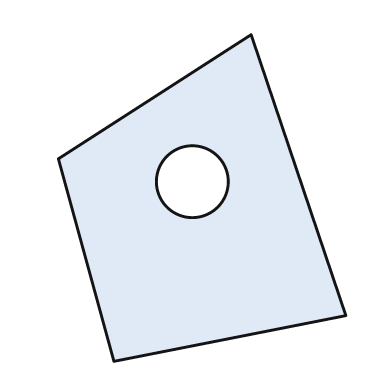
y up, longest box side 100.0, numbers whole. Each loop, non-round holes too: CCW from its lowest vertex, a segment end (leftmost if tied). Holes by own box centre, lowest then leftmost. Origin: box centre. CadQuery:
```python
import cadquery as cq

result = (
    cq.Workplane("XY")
    .moveTo(-27.0, -50.0)
    .lineTo(44.0, -36.0)
    .lineTo(15.0, 50.0)
    .lineTo(-44.0, 12.0)
    .close()
    .moveTo(-3.0, 5.0)
    .circle(11.0)
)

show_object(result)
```